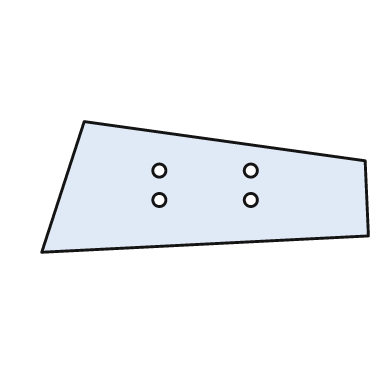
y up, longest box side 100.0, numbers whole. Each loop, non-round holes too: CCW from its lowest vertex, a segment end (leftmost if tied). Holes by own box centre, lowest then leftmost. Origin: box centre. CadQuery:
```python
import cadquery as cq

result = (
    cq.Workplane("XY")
    .moveTo(-50.0, -20.0)
    .lineTo(50.0, -15.0)
    .lineTo(49.0, 8.0)
    .lineTo(-37.0, 20.0)
    .close()
    .moveTo(-14.0, -4.0)
    .circle(2.0)
    .moveTo(14.0, -4.0)
    .circle(2.0)
    .moveTo(-14.0, 5.0)
    .circle(2.0)
    .moveTo(14.0, 5.0)
    .circle(2.0)
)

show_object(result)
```